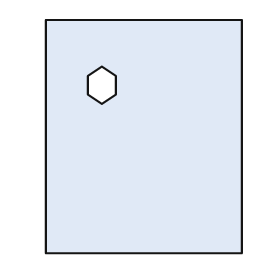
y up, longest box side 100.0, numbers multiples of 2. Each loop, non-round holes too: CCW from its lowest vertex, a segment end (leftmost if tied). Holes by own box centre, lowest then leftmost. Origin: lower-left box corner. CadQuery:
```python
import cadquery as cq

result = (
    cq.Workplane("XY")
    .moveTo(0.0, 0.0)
    .lineTo(84.0, 0.0)
    .lineTo(84.0, 100.0)
    .lineTo(0.0, 100.0)
    .close()
    .moveTo(24.0, 64.0)
    .lineTo(30.0, 68.0)
    .lineTo(30.0, 76.0)
    .lineTo(24.0, 80.0)
    .lineTo(18.0, 76.0)
    .lineTo(18.0, 68.0)
    .close()
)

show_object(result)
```